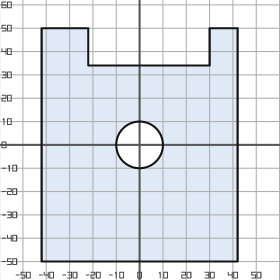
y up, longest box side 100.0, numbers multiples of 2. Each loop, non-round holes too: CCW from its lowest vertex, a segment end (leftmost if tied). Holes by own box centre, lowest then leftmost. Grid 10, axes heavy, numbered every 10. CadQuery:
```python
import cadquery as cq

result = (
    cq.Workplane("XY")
    .moveTo(-42.0, -50.0)
    .lineTo(42.0, -50.0)
    .lineTo(42.0, 50.0)
    .lineTo(30.0, 50.0)
    .lineTo(30.0, 34.0)
    .lineTo(-22.0, 34.0)
    .lineTo(-22.0, 50.0)
    .lineTo(-42.0, 50.0)
    .close()
    .moveTo(0.0, 0.0)
    .circle(10.0)
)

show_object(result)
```